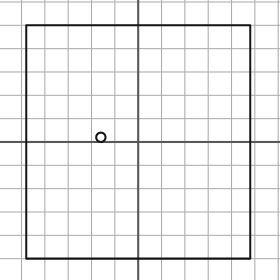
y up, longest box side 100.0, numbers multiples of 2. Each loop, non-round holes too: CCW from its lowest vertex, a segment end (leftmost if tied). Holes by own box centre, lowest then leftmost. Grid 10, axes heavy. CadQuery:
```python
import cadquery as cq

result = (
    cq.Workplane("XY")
    .moveTo(-48.0, -50.0)
    .lineTo(48.0, -50.0)
    .lineTo(48.0, 50.0)
    .lineTo(-48.0, 50.0)
    .close()
    .moveTo(-16.0, 2.0)
    .circle(2.0)
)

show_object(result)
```